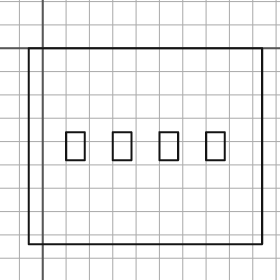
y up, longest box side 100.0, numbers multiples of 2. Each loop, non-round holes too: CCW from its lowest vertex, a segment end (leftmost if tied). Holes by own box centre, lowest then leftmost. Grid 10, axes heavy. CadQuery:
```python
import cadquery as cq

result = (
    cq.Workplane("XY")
    .moveTo(-6.0, -84.0)
    .lineTo(94.0, -84.0)
    .lineTo(94.0, 0.0)
    .lineTo(-6.0, 0.0)
    .close()
    .moveTo(10.0, -48.0)
    .lineTo(18.0, -48.0)
    .lineTo(18.0, -36.0)
    .lineTo(10.0, -36.0)
    .close()
    .moveTo(30.0, -48.0)
    .lineTo(38.0, -48.0)
    .lineTo(38.0, -36.0)
    .lineTo(30.0, -36.0)
    .close()
    .moveTo(50.0, -48.0)
    .lineTo(58.0, -48.0)
    .lineTo(58.0, -36.0)
    .lineTo(50.0, -36.0)
    .close()
    .moveTo(70.0, -48.0)
    .lineTo(78.0, -48.0)
    .lineTo(78.0, -36.0)
    .lineTo(70.0, -36.0)
    .close()
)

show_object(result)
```